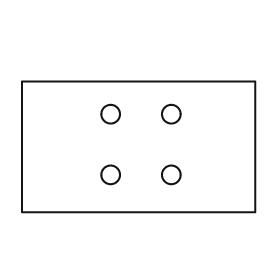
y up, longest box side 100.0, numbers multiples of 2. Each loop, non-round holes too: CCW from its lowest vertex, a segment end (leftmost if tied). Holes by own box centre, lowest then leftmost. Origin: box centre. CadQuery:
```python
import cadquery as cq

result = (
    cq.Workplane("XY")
    .moveTo(-50.0, -28.0)
    .lineTo(50.0, -28.0)
    .lineTo(50.0, 28.0)
    .lineTo(-50.0, 28.0)
    .close()
    .moveTo(-12.0, -12.0)
    .circle(4.0)
    .moveTo(14.0, -12.0)
    .circle(4.0)
    .moveTo(-12.0, 14.0)
    .circle(4.0)
    .moveTo(14.0, 14.0)
    .circle(4.0)
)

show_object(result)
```